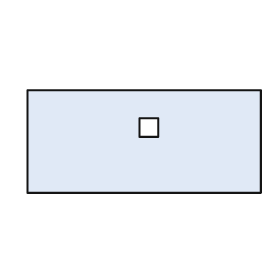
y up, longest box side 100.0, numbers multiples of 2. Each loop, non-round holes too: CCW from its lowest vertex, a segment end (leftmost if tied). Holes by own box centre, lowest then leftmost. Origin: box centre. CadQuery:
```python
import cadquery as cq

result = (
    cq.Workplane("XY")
    .moveTo(-50.0, -22.0)
    .lineTo(50.0, -22.0)
    .lineTo(50.0, 22.0)
    .lineTo(-50.0, 22.0)
    .close()
    .moveTo(-2.0, 2.0)
    .lineTo(6.0, 2.0)
    .lineTo(6.0, 10.0)
    .lineTo(-2.0, 10.0)
    .close()
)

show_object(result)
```